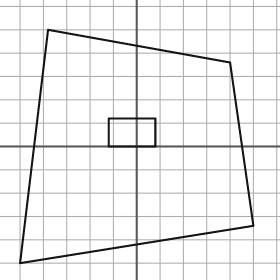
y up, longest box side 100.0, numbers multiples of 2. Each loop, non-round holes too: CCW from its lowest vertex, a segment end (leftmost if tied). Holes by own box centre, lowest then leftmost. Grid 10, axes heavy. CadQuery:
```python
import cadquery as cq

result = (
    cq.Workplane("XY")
    .moveTo(-50.0, -50.0)
    .lineTo(50.0, -34.0)
    .lineTo(40.0, 36.0)
    .lineTo(-38.0, 50.0)
    .close()
    .moveTo(-12.0, 0.0)
    .lineTo(8.0, 0.0)
    .lineTo(8.0, 12.0)
    .lineTo(-12.0, 12.0)
    .close()
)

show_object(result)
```